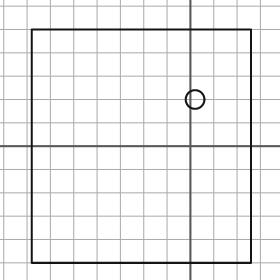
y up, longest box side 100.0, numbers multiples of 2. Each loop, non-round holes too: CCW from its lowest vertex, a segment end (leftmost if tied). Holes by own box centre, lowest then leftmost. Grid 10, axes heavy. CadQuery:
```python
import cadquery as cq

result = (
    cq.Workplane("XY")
    .moveTo(-68.0, -50.0)
    .lineTo(26.0, -50.0)
    .lineTo(26.0, 50.0)
    .lineTo(-68.0, 50.0)
    .close()
    .moveTo(2.0, 20.0)
    .circle(4.0)
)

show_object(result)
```